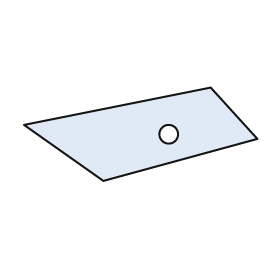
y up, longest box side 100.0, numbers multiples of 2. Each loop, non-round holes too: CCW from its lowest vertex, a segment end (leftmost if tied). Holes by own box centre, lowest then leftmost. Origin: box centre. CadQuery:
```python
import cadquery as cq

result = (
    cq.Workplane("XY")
    .moveTo(-16.0, -20.0)
    .lineTo(50.0, -2.0)
    .lineTo(30.0, 20.0)
    .lineTo(-50.0, 4.0)
    .close()
    .moveTo(12.0, 0.0)
    .circle(4.0)
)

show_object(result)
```